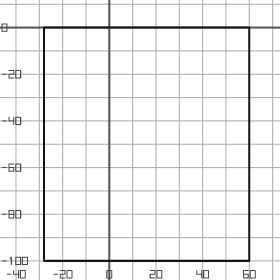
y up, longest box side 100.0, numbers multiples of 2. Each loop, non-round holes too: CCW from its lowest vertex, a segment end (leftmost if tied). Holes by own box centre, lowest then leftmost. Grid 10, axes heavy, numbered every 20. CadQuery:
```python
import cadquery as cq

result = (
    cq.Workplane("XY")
    .moveTo(-28.0, -100.0)
    .lineTo(60.0, -100.0)
    .lineTo(60.0, 0.0)
    .lineTo(-28.0, 0.0)
    .close()
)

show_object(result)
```